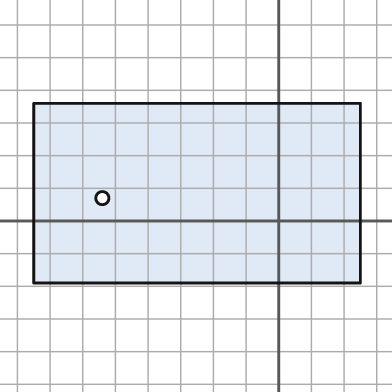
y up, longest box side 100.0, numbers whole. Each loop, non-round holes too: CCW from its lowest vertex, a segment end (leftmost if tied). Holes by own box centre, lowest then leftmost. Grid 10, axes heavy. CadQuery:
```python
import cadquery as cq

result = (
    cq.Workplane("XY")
    .moveTo(-75.0, -19.0)
    .lineTo(25.0, -19.0)
    .lineTo(25.0, 36.0)
    .lineTo(-75.0, 36.0)
    .close()
    .moveTo(-54.0, 7.0)
    .circle(2.0)
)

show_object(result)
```